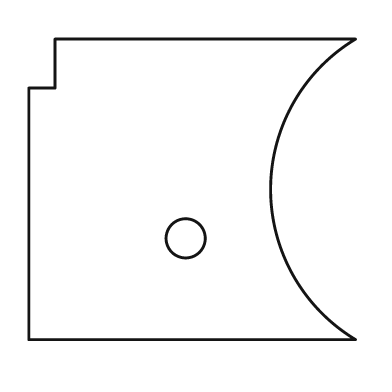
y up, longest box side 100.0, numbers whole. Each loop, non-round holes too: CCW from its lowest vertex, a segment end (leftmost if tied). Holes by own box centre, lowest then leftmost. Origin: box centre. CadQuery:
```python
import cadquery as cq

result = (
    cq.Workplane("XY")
    .moveTo(-50.0, -46.0)
    .lineTo(50.0, -46.0)
    .threePointArc((24.0, 0.0), (50.0, 46.0))
    .lineTo(-42.0, 46.0)
    .lineTo(-42.0, 31.0)
    .lineTo(-50.0, 31.0)
    .close()
    .moveTo(-2.0, -15.0)
    .circle(6.0)
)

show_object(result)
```